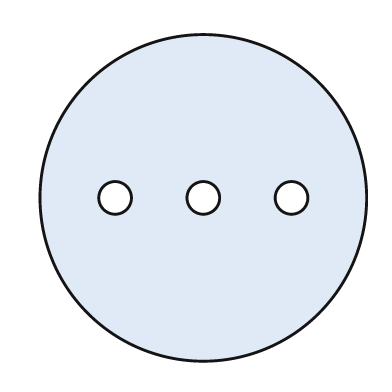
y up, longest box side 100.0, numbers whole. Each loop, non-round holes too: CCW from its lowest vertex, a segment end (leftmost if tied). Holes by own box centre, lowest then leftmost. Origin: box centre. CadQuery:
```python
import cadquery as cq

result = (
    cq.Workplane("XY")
    .moveTo(0.0, 0.0)
    .circle(50.0)
    .moveTo(-27.0, 0.0)
    .circle(5.0)
    .moveTo(0.0, 0.0)
    .circle(5.0)
    .moveTo(27.0, 0.0)
    .circle(5.0)
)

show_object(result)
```